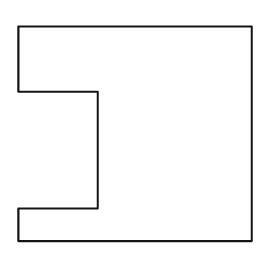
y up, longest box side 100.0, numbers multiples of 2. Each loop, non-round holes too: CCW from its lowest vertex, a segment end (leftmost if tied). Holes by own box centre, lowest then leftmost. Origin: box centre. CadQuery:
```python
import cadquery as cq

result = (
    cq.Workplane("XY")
    .moveTo(-50.0, -46.0)
    .lineTo(50.0, -46.0)
    .lineTo(50.0, 46.0)
    .lineTo(-50.0, 46.0)
    .lineTo(-50.0, 18.0)
    .lineTo(-16.0, 18.0)
    .lineTo(-16.0, -32.0)
    .lineTo(-50.0, -32.0)
    .close()
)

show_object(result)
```